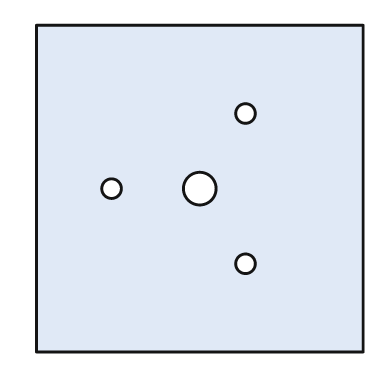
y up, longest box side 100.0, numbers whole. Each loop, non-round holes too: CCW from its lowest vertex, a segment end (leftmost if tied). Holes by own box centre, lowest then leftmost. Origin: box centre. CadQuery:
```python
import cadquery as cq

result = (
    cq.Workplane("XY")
    .moveTo(-50.0, -50.0)
    .lineTo(50.0, -50.0)
    .lineTo(50.0, 50.0)
    .lineTo(-50.0, 50.0)
    .close()
    .moveTo(14.0, -23.0)
    .circle(3.0)
    .moveTo(-27.0, 0.0)
    .circle(3.0)
    .moveTo(0.0, 0.0)
    .circle(5.0)
    .moveTo(14.0, 23.0)
    .circle(3.0)
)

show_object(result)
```